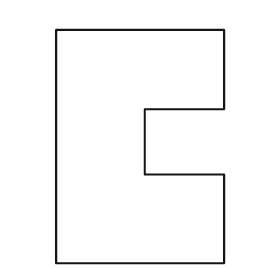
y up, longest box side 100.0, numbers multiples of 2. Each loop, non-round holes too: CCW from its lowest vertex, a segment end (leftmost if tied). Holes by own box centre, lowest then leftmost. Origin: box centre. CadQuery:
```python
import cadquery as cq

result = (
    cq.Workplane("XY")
    .moveTo(-36.0, -50.0)
    .lineTo(36.0, -50.0)
    .lineTo(36.0, -12.0)
    .lineTo(2.0, -12.0)
    .lineTo(2.0, 16.0)
    .lineTo(36.0, 16.0)
    .lineTo(36.0, 50.0)
    .lineTo(-36.0, 50.0)
    .close()
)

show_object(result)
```